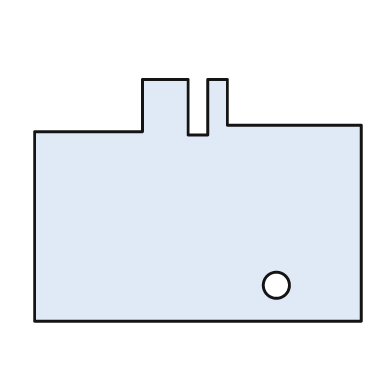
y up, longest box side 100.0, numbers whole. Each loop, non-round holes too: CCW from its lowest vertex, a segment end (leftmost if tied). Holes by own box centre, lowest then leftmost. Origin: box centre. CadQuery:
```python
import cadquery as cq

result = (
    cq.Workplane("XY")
    .moveTo(-50.0, -37.0)
    .lineTo(50.0, -37.0)
    .lineTo(50.0, 23.0)
    .lineTo(9.0, 23.0)
    .lineTo(9.0, 37.0)
    .lineTo(3.0, 37.0)
    .lineTo(3.0, 20.0)
    .lineTo(-3.0, 20.0)
    .lineTo(-3.0, 37.0)
    .lineTo(-17.0, 37.0)
    .lineTo(-17.0, 21.0)
    .lineTo(-50.0, 21.0)
    .close()
    .moveTo(24.0, -26.0)
    .circle(4.0)
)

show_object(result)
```